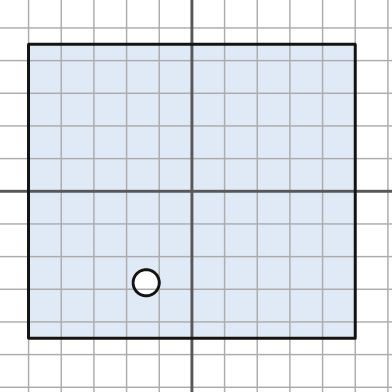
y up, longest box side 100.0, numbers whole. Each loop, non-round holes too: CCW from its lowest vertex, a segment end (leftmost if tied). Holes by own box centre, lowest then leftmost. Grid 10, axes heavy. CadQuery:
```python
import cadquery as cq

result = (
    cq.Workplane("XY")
    .moveTo(-50.0, -45.0)
    .lineTo(50.0, -45.0)
    .lineTo(50.0, 45.0)
    .lineTo(-50.0, 45.0)
    .close()
    .moveTo(-14.0, -28.0)
    .circle(4.0)
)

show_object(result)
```